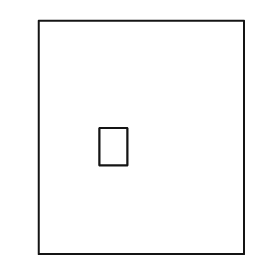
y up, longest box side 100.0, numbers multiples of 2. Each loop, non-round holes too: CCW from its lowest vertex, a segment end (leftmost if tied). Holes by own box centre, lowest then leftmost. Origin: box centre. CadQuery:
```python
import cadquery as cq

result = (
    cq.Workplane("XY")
    .moveTo(-44.0, -50.0)
    .lineTo(44.0, -50.0)
    .lineTo(44.0, 50.0)
    .lineTo(-44.0, 50.0)
    .close()
    .moveTo(-18.0, -12.0)
    .lineTo(-6.0, -12.0)
    .lineTo(-6.0, 4.0)
    .lineTo(-18.0, 4.0)
    .close()
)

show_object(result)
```